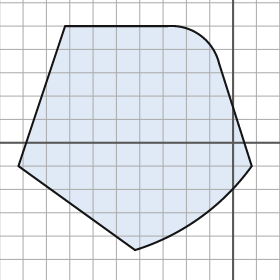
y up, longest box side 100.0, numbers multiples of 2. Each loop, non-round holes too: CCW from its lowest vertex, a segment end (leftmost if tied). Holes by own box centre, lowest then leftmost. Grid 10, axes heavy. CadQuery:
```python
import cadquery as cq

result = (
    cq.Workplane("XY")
    .moveTo(-42.0, -46.0)
    .threePointArc((-14.0, -32.0), (8.0, -10.0))
    .lineTo(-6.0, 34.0)
    .threePointArc((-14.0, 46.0), (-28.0, 50.0))
    .lineTo(-72.0, 50.0)
    .lineTo(-92.0, -10.0)
    .close()
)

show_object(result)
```